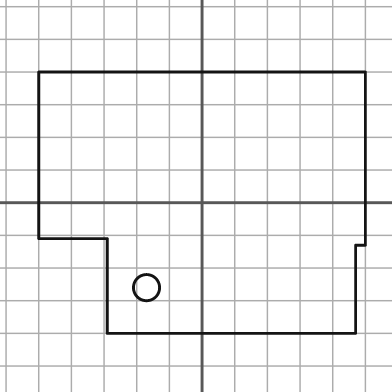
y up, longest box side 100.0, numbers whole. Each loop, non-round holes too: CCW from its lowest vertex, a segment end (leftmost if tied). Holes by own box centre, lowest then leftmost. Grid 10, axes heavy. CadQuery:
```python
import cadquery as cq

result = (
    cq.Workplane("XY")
    .moveTo(-29.0, -40.0)
    .lineTo(47.0, -40.0)
    .lineTo(47.0, -13.0)
    .lineTo(50.0, -13.0)
    .lineTo(50.0, 40.0)
    .lineTo(-50.0, 40.0)
    .lineTo(-50.0, -11.0)
    .lineTo(-29.0, -11.0)
    .close()
    .moveTo(-17.0, -26.0)
    .circle(4.0)
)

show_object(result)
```